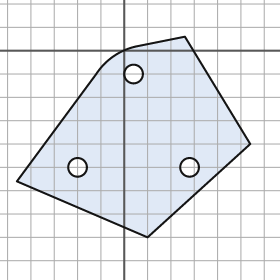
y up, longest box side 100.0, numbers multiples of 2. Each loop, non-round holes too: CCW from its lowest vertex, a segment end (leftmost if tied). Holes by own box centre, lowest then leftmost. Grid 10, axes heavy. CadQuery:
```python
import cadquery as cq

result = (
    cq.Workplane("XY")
    .moveTo(10.0, -80.0)
    .lineTo(54.0, -40.0)
    .lineTo(26.0, 6.0)
    .lineTo(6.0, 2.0)
    .threePointArc((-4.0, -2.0), (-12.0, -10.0))
    .lineTo(-46.0, -56.0)
    .close()
    .moveTo(-20.0, -50.0)
    .circle(4.0)
    .moveTo(28.0, -50.0)
    .circle(4.0)
    .moveTo(4.0, -10.0)
    .circle(4.0)
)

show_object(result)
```